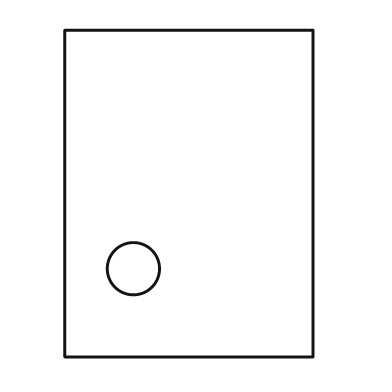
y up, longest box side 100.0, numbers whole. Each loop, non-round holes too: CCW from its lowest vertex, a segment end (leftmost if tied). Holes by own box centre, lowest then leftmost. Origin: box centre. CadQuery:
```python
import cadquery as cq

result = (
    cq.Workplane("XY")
    .moveTo(-38.0, -50.0)
    .lineTo(38.0, -50.0)
    .lineTo(38.0, 50.0)
    .lineTo(-38.0, 50.0)
    .close()
    .moveTo(-17.0, -23.0)
    .circle(8.0)
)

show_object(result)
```